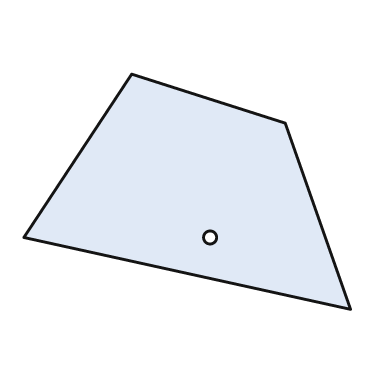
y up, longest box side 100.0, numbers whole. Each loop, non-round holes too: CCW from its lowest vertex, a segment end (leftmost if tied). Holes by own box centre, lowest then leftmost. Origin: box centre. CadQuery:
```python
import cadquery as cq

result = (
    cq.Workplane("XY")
    .moveTo(50.0, -36.0)
    .lineTo(30.0, 21.0)
    .lineTo(-17.0, 36.0)
    .lineTo(-50.0, -14.0)
    .close()
    .moveTo(7.0, -14.0)
    .circle(2.0)
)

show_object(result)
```